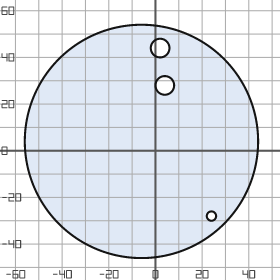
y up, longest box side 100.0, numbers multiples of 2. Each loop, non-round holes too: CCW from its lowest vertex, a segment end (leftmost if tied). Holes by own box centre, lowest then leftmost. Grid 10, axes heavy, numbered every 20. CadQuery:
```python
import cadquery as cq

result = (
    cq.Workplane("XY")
    .moveTo(-6.0, 4.0)
    .circle(50.0)
    .moveTo(24.0, -28.0)
    .circle(2.0)
    .moveTo(4.0, 28.0)
    .circle(4.0)
    .moveTo(2.0, 44.0)
    .circle(4.0)
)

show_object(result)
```